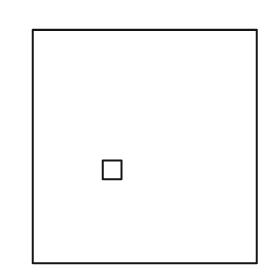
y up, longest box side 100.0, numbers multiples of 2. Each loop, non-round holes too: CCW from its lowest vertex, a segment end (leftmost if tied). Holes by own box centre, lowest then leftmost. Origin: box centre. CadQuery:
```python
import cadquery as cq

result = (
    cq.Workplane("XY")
    .moveTo(-48.0, -50.0)
    .lineTo(48.0, -50.0)
    .lineTo(48.0, 50.0)
    .lineTo(-48.0, 50.0)
    .close()
    .moveTo(-18.0, -14.0)
    .lineTo(-10.0, -14.0)
    .lineTo(-10.0, -6.0)
    .lineTo(-18.0, -6.0)
    .close()
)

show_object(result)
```